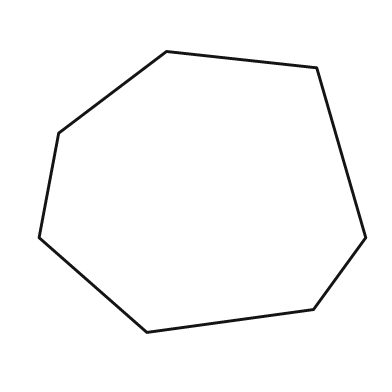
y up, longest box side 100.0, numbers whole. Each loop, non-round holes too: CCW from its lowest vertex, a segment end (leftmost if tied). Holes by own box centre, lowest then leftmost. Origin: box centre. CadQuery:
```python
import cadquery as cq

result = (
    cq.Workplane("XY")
    .moveTo(-17.0, -43.0)
    .lineTo(34.0, -36.0)
    .lineTo(50.0, -14.0)
    .lineTo(35.0, 38.0)
    .lineTo(-11.0, 43.0)
    .lineTo(-44.0, 18.0)
    .lineTo(-50.0, -14.0)
    .close()
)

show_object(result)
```